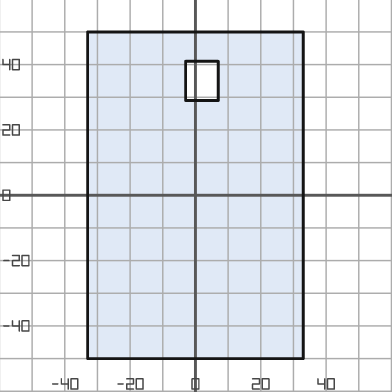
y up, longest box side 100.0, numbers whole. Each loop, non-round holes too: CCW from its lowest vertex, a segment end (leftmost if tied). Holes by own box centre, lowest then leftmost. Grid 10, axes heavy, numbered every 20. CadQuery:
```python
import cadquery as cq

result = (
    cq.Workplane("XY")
    .moveTo(-33.0, -50.0)
    .lineTo(33.0, -50.0)
    .lineTo(33.0, 50.0)
    .lineTo(-33.0, 50.0)
    .close()
    .moveTo(-3.0, 29.0)
    .lineTo(7.0, 29.0)
    .lineTo(7.0, 41.0)
    .lineTo(-3.0, 41.0)
    .close()
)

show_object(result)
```